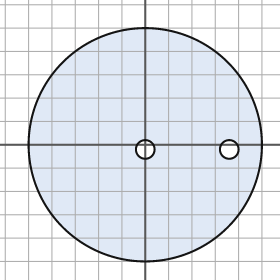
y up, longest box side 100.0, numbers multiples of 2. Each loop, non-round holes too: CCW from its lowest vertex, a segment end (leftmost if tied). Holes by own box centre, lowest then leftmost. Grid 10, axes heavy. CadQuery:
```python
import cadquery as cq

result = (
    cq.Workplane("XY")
    .moveTo(0.0, 0.0)
    .circle(50.0)
    .moveTo(0.0, -2.0)
    .circle(4.0)
    .moveTo(36.0, -2.0)
    .circle(4.0)
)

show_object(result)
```